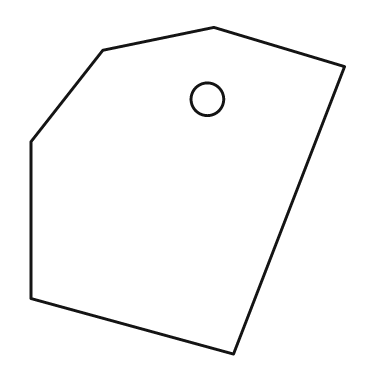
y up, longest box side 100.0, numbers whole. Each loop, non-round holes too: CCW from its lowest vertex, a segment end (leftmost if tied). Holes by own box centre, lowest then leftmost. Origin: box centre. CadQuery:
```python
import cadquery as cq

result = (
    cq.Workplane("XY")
    .moveTo(14.0, -50.0)
    .lineTo(48.0, 38.0)
    .lineTo(8.0, 50.0)
    .lineTo(-26.0, 43.0)
    .lineTo(-48.0, 15.0)
    .lineTo(-48.0, -33.0)
    .close()
    .moveTo(6.0, 28.0)
    .circle(5.0)
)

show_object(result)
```